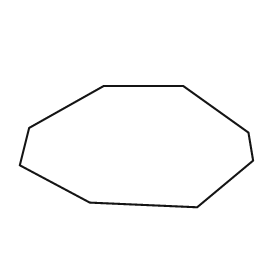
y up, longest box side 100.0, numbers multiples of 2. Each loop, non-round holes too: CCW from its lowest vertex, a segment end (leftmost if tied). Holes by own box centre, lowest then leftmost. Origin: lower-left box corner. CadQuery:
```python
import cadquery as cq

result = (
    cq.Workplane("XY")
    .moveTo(76.0, 0.0)
    .lineTo(100.0, 20.0)
    .lineTo(98.0, 32.0)
    .lineTo(70.0, 52.0)
    .lineTo(36.0, 52.0)
    .lineTo(4.0, 34.0)
    .lineTo(0.0, 18.0)
    .lineTo(30.0, 2.0)
    .close()
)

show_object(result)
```